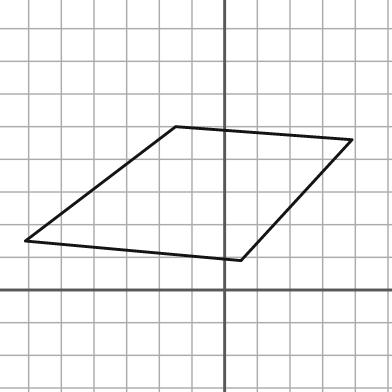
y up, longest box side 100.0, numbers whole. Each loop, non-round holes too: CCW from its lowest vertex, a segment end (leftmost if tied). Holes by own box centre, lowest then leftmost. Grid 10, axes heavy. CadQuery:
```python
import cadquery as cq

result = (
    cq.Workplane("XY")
    .moveTo(5.0, 9.0)
    .lineTo(39.0, 46.0)
    .lineTo(-15.0, 50.0)
    .lineTo(-61.0, 15.0)
    .close()
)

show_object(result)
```